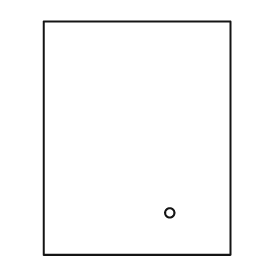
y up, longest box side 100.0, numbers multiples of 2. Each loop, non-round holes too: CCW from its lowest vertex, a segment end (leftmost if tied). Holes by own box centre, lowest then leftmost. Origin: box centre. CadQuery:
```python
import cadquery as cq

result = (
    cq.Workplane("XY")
    .moveTo(-40.0, -50.0)
    .lineTo(40.0, -50.0)
    .lineTo(40.0, 50.0)
    .lineTo(-40.0, 50.0)
    .close()
    .moveTo(14.0, -32.0)
    .circle(2.0)
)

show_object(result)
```